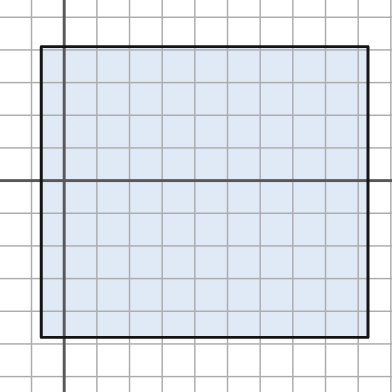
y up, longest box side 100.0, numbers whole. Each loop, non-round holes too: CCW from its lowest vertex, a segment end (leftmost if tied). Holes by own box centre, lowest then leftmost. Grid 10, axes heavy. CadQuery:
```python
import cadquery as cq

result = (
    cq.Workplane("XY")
    .moveTo(-7.0, -48.0)
    .lineTo(93.0, -48.0)
    .lineTo(93.0, 41.0)
    .lineTo(-7.0, 41.0)
    .close()
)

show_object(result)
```